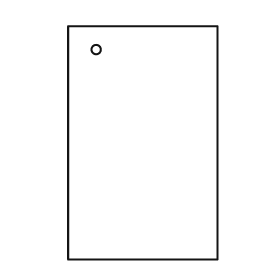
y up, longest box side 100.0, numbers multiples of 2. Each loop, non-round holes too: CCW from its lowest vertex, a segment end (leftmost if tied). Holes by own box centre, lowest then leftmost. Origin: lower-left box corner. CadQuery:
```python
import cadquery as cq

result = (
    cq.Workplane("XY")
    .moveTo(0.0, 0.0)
    .lineTo(64.0, 0.0)
    .lineTo(64.0, 100.0)
    .lineTo(0.0, 100.0)
    .close()
    .moveTo(12.0, 90.0)
    .circle(2.0)
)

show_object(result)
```